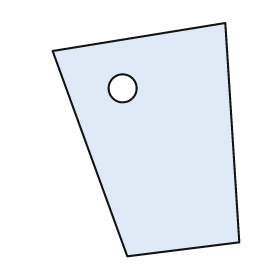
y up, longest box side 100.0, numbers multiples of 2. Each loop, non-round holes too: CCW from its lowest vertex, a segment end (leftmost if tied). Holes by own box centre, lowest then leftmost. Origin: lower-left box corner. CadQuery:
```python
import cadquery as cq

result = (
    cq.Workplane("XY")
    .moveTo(32.0, 0.0)
    .lineTo(80.0, 6.0)
    .lineTo(74.0, 100.0)
    .lineTo(0.0, 88.0)
    .close()
    .moveTo(30.0, 72.0)
    .circle(6.0)
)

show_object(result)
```